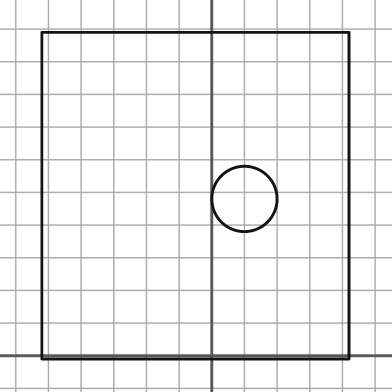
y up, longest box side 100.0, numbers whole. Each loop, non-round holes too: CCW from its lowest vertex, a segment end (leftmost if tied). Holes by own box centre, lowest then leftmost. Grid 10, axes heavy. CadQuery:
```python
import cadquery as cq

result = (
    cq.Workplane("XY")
    .moveTo(-52.0, -1.0)
    .lineTo(42.0, -1.0)
    .lineTo(42.0, 99.0)
    .lineTo(-52.0, 99.0)
    .close()
    .moveTo(10.0, 48.0)
    .circle(10.0)
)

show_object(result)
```